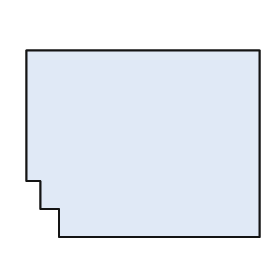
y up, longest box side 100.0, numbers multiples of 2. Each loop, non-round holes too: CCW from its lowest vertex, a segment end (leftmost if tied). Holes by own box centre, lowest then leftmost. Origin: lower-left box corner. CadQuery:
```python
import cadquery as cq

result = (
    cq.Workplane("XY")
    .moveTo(14.0, 0.0)
    .lineTo(100.0, 0.0)
    .lineTo(100.0, 80.0)
    .lineTo(0.0, 80.0)
    .lineTo(0.0, 24.0)
    .lineTo(6.0, 24.0)
    .lineTo(6.0, 12.0)
    .lineTo(14.0, 12.0)
    .close()
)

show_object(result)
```